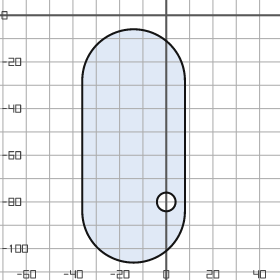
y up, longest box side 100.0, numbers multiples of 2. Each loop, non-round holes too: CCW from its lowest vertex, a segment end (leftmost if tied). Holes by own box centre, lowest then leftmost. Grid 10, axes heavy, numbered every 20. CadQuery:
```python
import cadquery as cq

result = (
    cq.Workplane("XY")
    .moveTo(-36.0, -84.0)
    .threePointArc((-14.0, -106.0), (8.0, -84.0))
    .lineTo(8.0, -28.0)
    .threePointArc((-14.0, -6.0), (-36.0, -28.0))
    .close()
    .moveTo(0.0, -80.0)
    .circle(4.0)
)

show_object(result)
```